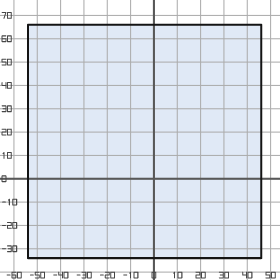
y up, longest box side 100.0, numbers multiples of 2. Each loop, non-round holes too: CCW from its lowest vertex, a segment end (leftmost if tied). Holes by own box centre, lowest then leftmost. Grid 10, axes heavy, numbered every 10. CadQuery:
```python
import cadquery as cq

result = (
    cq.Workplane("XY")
    .moveTo(-54.0, -34.0)
    .lineTo(46.0, -34.0)
    .lineTo(46.0, 66.0)
    .lineTo(-54.0, 66.0)
    .close()
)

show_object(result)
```